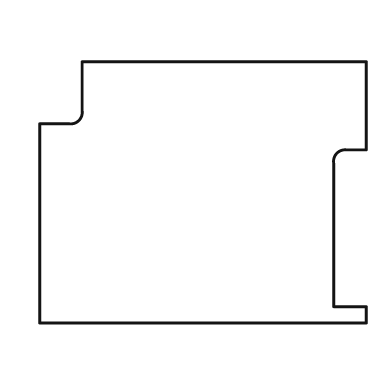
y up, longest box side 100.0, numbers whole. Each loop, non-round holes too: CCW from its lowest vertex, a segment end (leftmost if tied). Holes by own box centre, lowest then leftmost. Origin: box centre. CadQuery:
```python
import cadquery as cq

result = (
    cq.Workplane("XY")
    .moveTo(-50.0, -40.0)
    .lineTo(50.0, -40.0)
    .lineTo(50.0, -35.0)
    .lineTo(40.0, -35.0)
    .lineTo(40.0, 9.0)
    .threePointArc((41.0, 12.0), (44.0, 13.0))
    .lineTo(50.0, 13.0)
    .lineTo(50.0, 40.0)
    .lineTo(-37.0, 40.0)
    .lineTo(-37.0, 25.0)
    .threePointArc((-38.0, 22.0), (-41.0, 21.0))
    .lineTo(-50.0, 21.0)
    .close()
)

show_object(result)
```